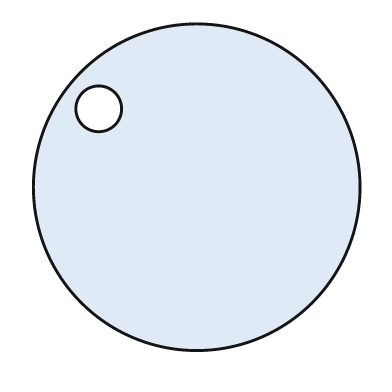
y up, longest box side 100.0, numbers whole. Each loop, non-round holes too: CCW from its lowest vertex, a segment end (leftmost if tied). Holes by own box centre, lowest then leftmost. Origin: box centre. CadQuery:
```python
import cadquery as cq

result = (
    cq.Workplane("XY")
    .moveTo(0.0, 0.0)
    .circle(50.0)
    .moveTo(-30.0, 24.0)
    .circle(7.0)
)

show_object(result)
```